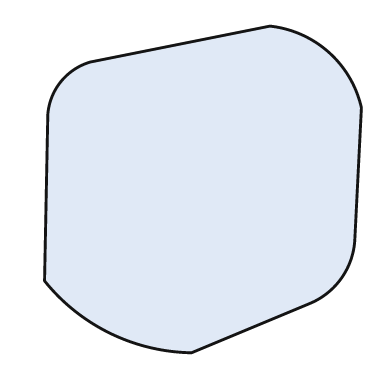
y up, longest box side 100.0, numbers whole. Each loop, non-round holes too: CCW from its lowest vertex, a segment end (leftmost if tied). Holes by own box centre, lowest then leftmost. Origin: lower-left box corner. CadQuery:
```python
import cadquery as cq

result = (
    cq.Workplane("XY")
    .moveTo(45.0, 0.0)
    .lineTo(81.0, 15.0)
    .threePointArc((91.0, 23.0), (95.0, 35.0))
    .lineTo(97.0, 75.0)
    .threePointArc((87.0, 92.0), (69.0, 100.0))
    .lineTo(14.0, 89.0)
    .threePointArc((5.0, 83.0), (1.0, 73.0))
    .lineTo(0.0, 22.0)
    .threePointArc((20.0, 6.0), (45.0, 0.0))
    .close()
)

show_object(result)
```